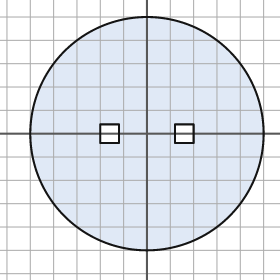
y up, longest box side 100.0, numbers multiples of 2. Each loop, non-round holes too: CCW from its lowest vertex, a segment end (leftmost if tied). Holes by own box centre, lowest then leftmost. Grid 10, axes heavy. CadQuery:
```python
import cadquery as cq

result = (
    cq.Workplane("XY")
    .moveTo(0.0, 0.0)
    .circle(50.0)
    .moveTo(-20.0, -4.0)
    .lineTo(-12.0, -4.0)
    .lineTo(-12.0, 4.0)
    .lineTo(-20.0, 4.0)
    .close()
    .moveTo(12.0, -4.0)
    .lineTo(20.0, -4.0)
    .lineTo(20.0, 4.0)
    .lineTo(12.0, 4.0)
    .close()
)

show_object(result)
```